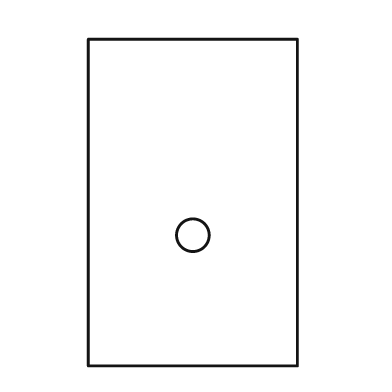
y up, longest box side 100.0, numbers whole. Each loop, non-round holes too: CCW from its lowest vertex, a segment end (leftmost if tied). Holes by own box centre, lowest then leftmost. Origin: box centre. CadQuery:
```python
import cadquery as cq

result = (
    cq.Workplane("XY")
    .moveTo(-32.0, -50.0)
    .lineTo(32.0, -50.0)
    .lineTo(32.0, 50.0)
    .lineTo(-32.0, 50.0)
    .close()
    .moveTo(0.0, -10.0)
    .circle(5.0)
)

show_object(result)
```